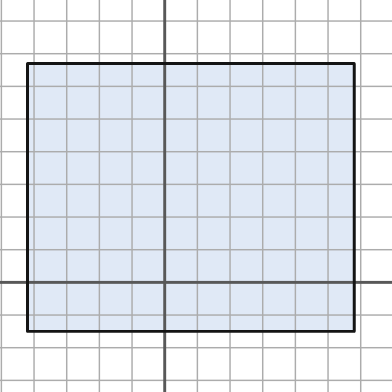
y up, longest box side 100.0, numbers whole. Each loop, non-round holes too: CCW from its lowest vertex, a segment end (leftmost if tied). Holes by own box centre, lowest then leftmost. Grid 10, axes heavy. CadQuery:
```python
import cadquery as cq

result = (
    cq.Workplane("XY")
    .moveTo(-42.0, -15.0)
    .lineTo(58.0, -15.0)
    .lineTo(58.0, 67.0)
    .lineTo(-42.0, 67.0)
    .close()
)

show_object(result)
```